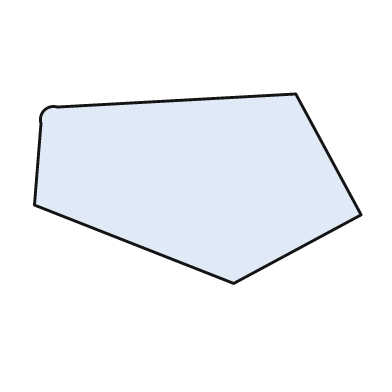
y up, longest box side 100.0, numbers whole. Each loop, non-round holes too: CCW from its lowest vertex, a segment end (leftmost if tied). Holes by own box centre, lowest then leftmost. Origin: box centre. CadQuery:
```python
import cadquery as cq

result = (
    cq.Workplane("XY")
    .moveTo(11.0, -29.0)
    .lineTo(50.0, -8.0)
    .lineTo(30.0, 29.0)
    .lineTo(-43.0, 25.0)
    .threePointArc((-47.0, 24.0), (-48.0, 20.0))
    .lineTo(-50.0, -5.0)
    .close()
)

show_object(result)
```